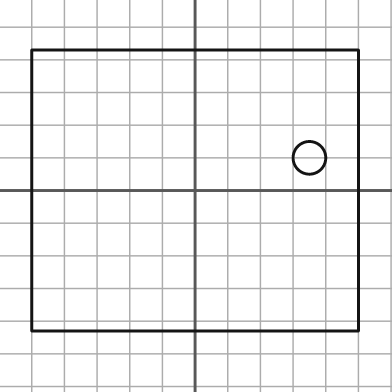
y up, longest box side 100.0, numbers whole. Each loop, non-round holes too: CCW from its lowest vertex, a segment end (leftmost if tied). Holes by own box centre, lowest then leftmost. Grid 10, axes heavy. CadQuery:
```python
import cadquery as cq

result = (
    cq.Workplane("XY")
    .moveTo(-50.0, -43.0)
    .lineTo(50.0, -43.0)
    .lineTo(50.0, 43.0)
    .lineTo(-50.0, 43.0)
    .close()
    .moveTo(35.0, 10.0)
    .circle(5.0)
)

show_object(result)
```